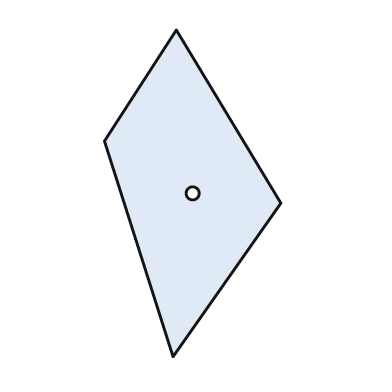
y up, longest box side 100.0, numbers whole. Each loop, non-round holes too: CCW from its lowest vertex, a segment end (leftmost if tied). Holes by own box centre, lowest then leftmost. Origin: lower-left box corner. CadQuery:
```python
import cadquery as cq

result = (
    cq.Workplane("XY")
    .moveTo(21.0, 0.0)
    .lineTo(54.0, 47.0)
    .lineTo(22.0, 100.0)
    .lineTo(0.0, 66.0)
    .close()
    .moveTo(27.0, 50.0)
    .circle(2.0)
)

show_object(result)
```